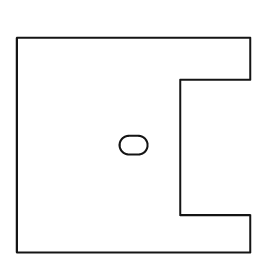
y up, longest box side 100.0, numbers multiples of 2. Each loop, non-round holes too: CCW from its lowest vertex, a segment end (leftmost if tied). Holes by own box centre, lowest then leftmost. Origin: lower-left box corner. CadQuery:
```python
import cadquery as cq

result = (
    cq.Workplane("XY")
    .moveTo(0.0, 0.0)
    .lineTo(100.0, 0.0)
    .lineTo(100.0, 16.0)
    .lineTo(70.0, 16.0)
    .lineTo(70.0, 74.0)
    .lineTo(100.0, 74.0)
    .lineTo(100.0, 92.0)
    .lineTo(0.0, 92.0)
    .close()
    .moveTo(48.0, 42.0)
    .lineTo(52.0, 42.0)
    .threePointArc((56.0, 46.0), (52.0, 50.0))
    .lineTo(48.0, 50.0)
    .threePointArc((44.0, 46.0), (48.0, 42.0))
    .close()
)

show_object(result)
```